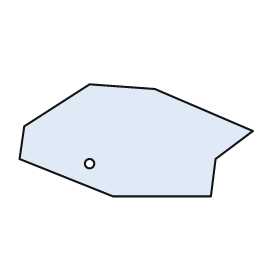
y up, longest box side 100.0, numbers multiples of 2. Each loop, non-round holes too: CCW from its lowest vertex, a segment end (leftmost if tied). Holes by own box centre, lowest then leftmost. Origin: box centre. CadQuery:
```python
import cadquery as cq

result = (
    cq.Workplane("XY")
    .moveTo(-10.0, -24.0)
    .lineTo(32.0, -24.0)
    .lineTo(34.0, -8.0)
    .lineTo(50.0, 4.0)
    .lineTo(8.0, 22.0)
    .lineTo(-20.0, 24.0)
    .lineTo(-48.0, 6.0)
    .lineTo(-50.0, -8.0)
    .close()
    .moveTo(-20.0, -10.0)
    .circle(2.0)
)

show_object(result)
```